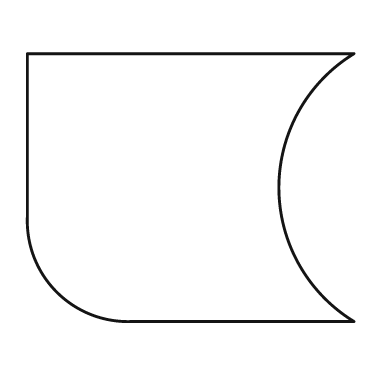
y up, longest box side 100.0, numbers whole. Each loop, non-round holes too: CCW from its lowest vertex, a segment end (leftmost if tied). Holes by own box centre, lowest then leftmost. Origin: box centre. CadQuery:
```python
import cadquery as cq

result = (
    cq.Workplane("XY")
    .moveTo(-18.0, -41.0)
    .lineTo(50.0, -41.0)
    .threePointArc((27.0, 0.0), (50.0, 41.0))
    .lineTo(-50.0, 41.0)
    .lineTo(-50.0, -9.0)
    .threePointArc((-41.0, -32.0), (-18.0, -41.0))
    .close()
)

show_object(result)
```